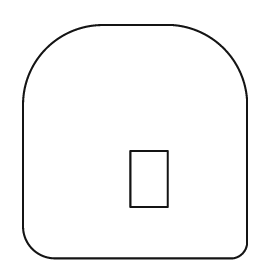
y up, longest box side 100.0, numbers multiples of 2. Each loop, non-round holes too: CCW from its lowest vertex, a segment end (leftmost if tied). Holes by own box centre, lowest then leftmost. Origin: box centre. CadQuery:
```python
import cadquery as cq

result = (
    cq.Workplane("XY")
    .moveTo(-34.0, -50.0)
    .lineTo(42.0, -50.0)
    .threePointArc((46.0, -48.0), (48.0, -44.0))
    .lineTo(48.0, 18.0)
    .threePointArc((38.0, 40.0), (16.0, 50.0))
    .lineTo(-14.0, 50.0)
    .threePointArc((-38.0, 40.0), (-48.0, 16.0))
    .lineTo(-48.0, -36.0)
    .threePointArc((-44.0, -46.0), (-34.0, -50.0))
    .close()
    .moveTo(-2.0, -28.0)
    .lineTo(14.0, -28.0)
    .lineTo(14.0, -4.0)
    .lineTo(-2.0, -4.0)
    .close()
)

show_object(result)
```